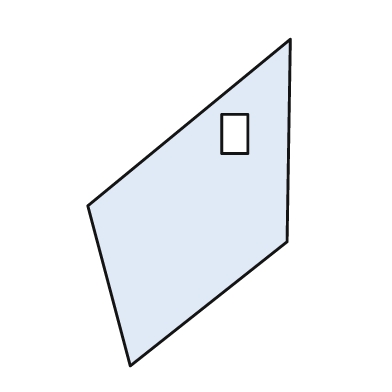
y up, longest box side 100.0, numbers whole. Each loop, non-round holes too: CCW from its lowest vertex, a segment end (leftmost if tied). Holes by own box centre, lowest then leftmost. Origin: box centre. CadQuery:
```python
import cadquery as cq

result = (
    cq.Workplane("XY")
    .moveTo(-18.0, -50.0)
    .lineTo(30.0, -12.0)
    .lineTo(31.0, 50.0)
    .lineTo(-31.0, -1.0)
    .close()
    .moveTo(10.0, 15.0)
    .lineTo(18.0, 15.0)
    .lineTo(18.0, 27.0)
    .lineTo(10.0, 27.0)
    .close()
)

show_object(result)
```